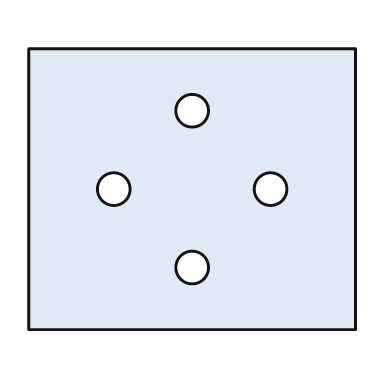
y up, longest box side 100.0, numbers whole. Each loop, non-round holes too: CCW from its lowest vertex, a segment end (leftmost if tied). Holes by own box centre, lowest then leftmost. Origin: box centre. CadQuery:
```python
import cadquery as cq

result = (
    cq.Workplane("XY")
    .moveTo(-50.0, -43.0)
    .lineTo(50.0, -43.0)
    .lineTo(50.0, 43.0)
    .lineTo(-50.0, 43.0)
    .close()
    .moveTo(0.0, -24.0)
    .circle(5.0)
    .moveTo(-24.0, 0.0)
    .circle(5.0)
    .moveTo(24.0, 0.0)
    .circle(5.0)
    .moveTo(0.0, 24.0)
    .circle(5.0)
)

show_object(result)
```